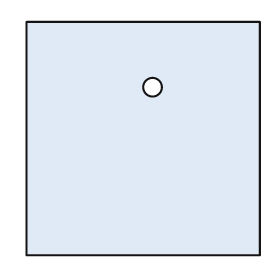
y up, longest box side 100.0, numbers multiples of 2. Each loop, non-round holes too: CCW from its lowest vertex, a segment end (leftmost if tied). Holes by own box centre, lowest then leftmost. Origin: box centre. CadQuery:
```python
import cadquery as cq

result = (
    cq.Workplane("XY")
    .moveTo(-50.0, -50.0)
    .lineTo(50.0, -50.0)
    .lineTo(50.0, 50.0)
    .lineTo(-50.0, 50.0)
    .close()
    .moveTo(4.0, 22.0)
    .circle(4.0)
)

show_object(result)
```